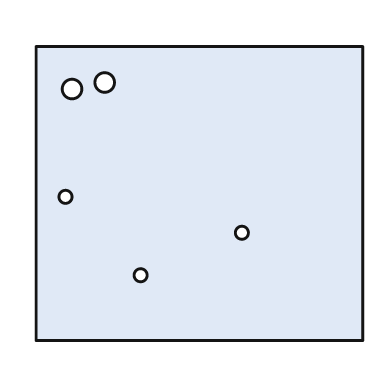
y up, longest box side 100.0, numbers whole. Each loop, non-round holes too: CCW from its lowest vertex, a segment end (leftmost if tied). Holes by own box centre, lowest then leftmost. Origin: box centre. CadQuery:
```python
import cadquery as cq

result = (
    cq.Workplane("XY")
    .moveTo(-50.0, -45.0)
    .lineTo(50.0, -45.0)
    .lineTo(50.0, 45.0)
    .lineTo(-50.0, 45.0)
    .close()
    .moveTo(-18.0, -25.0)
    .circle(2.0)
    .moveTo(13.0, -12.0)
    .circle(2.0)
    .moveTo(-41.0, -1.0)
    .circle(2.0)
    .moveTo(-39.0, 32.0)
    .circle(3.0)
    .moveTo(-29.0, 34.0)
    .circle(3.0)
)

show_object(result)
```